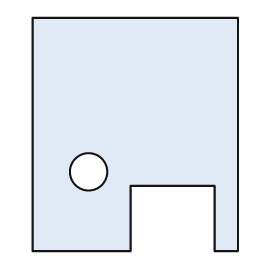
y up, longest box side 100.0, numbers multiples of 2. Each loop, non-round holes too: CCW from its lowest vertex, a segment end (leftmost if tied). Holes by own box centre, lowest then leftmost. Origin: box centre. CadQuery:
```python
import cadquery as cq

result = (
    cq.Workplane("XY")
    .moveTo(-44.0, -50.0)
    .lineTo(-2.0, -50.0)
    .lineTo(-2.0, -22.0)
    .lineTo(34.0, -22.0)
    .lineTo(34.0, -50.0)
    .lineTo(44.0, -50.0)
    .lineTo(44.0, 50.0)
    .lineTo(-44.0, 50.0)
    .close()
    .moveTo(-20.0, -16.0)
    .circle(8.0)
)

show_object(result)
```